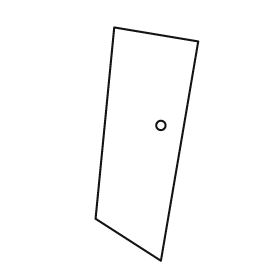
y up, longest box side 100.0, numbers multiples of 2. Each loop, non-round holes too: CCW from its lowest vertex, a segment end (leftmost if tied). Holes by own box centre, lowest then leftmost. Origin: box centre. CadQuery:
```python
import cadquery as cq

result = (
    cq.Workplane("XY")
    .moveTo(6.0, -50.0)
    .lineTo(22.0, 44.0)
    .lineTo(-14.0, 50.0)
    .lineTo(-22.0, -32.0)
    .close()
    .moveTo(6.0, 8.0)
    .circle(2.0)
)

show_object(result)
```